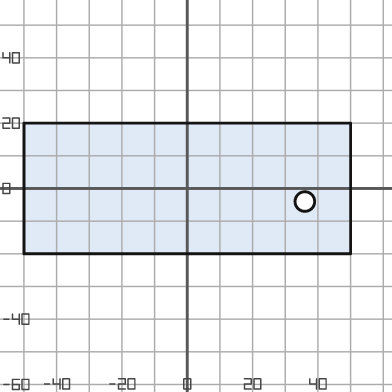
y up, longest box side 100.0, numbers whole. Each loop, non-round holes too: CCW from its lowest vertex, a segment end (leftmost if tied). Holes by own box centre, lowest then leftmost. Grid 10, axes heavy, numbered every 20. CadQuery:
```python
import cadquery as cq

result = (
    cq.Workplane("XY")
    .moveTo(-50.0, -20.0)
    .lineTo(50.0, -20.0)
    .lineTo(50.0, 20.0)
    .lineTo(-50.0, 20.0)
    .close()
    .moveTo(36.0, -4.0)
    .circle(3.0)
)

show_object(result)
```